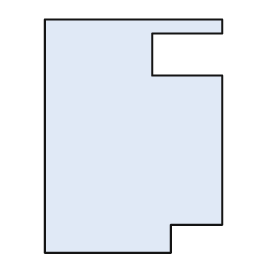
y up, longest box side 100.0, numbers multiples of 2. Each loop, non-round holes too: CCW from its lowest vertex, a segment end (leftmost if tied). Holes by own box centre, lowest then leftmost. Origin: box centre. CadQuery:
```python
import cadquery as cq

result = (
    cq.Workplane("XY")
    .moveTo(-38.0, -50.0)
    .lineTo(16.0, -50.0)
    .lineTo(16.0, -38.0)
    .lineTo(38.0, -38.0)
    .lineTo(38.0, 26.0)
    .lineTo(8.0, 26.0)
    .lineTo(8.0, 44.0)
    .lineTo(38.0, 44.0)
    .lineTo(38.0, 50.0)
    .lineTo(-38.0, 50.0)
    .close()
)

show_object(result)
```